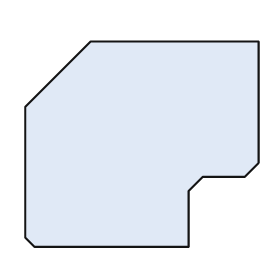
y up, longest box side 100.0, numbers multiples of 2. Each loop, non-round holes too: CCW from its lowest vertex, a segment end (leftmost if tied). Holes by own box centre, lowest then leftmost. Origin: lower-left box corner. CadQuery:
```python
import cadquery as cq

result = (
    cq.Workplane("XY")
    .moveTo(4.0, 0.0)
    .lineTo(70.0, 0.0)
    .lineTo(70.0, 24.0)
    .lineTo(76.0, 30.0)
    .lineTo(94.0, 30.0)
    .lineTo(100.0, 36.0)
    .lineTo(100.0, 88.0)
    .lineTo(28.0, 88.0)
    .lineTo(0.0, 60.0)
    .lineTo(0.0, 4.0)
    .close()
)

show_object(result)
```